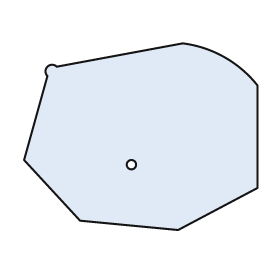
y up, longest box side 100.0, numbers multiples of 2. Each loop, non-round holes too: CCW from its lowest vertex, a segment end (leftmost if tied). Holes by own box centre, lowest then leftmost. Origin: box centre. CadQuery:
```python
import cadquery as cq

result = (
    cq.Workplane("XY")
    .moveTo(16.0, -40.0)
    .lineTo(50.0, -22.0)
    .lineTo(50.0, 22.0)
    .threePointArc((36.0, 34.0), (18.0, 40.0))
    .lineTo(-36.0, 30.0)
    .threePointArc((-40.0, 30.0), (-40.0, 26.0))
    .lineTo(-50.0, -10.0)
    .lineTo(-26.0, -36.0)
    .close()
    .moveTo(-4.0, -12.0)
    .circle(2.0)
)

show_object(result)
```